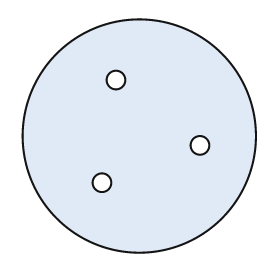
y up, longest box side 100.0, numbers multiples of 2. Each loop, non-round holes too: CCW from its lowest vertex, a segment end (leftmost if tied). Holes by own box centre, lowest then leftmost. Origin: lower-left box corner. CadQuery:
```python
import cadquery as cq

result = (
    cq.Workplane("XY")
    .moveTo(50.0, 50.0)
    .circle(50.0)
    .moveTo(34.0, 30.0)
    .circle(4.0)
    .moveTo(76.0, 46.0)
    .circle(4.0)
    .moveTo(40.0, 74.0)
    .circle(4.0)
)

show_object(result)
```